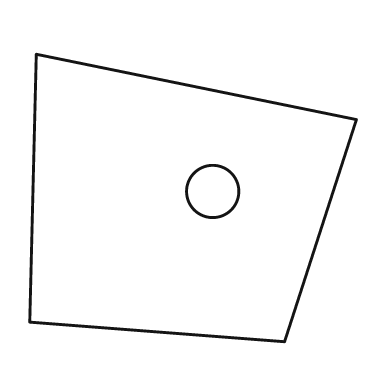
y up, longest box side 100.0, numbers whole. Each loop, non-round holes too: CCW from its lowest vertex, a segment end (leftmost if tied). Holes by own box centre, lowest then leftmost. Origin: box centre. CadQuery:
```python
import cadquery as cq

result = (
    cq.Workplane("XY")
    .moveTo(28.0, -44.0)
    .lineTo(50.0, 24.0)
    .lineTo(-48.0, 44.0)
    .lineTo(-50.0, -38.0)
    .close()
    .moveTo(6.0, 2.0)
    .circle(8.0)
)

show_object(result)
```